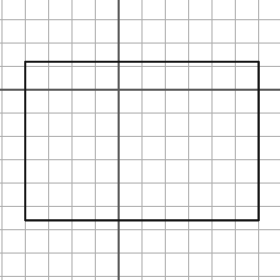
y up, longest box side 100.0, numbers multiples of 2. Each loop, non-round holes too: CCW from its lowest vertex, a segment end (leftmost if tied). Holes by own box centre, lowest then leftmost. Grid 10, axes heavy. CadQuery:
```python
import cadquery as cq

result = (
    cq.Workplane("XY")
    .moveTo(-40.0, -56.0)
    .lineTo(60.0, -56.0)
    .lineTo(60.0, 12.0)
    .lineTo(-40.0, 12.0)
    .close()
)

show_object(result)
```